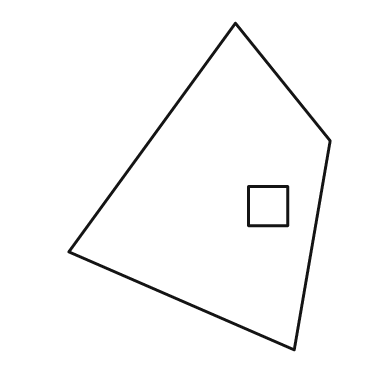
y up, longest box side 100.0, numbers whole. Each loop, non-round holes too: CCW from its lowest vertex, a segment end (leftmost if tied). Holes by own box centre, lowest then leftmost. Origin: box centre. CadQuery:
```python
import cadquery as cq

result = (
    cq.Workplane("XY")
    .moveTo(29.0, -50.0)
    .lineTo(40.0, 14.0)
    .lineTo(11.0, 50.0)
    .lineTo(-40.0, -20.0)
    .close()
    .moveTo(15.0, -12.0)
    .lineTo(27.0, -12.0)
    .lineTo(27.0, 0.0)
    .lineTo(15.0, 0.0)
    .close()
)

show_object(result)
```